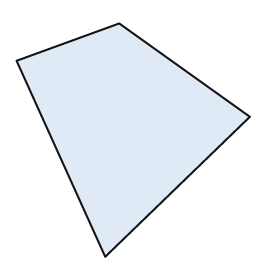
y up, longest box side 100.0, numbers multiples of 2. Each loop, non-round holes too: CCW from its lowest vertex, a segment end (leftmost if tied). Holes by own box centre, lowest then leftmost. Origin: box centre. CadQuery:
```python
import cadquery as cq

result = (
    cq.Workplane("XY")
    .moveTo(-12.0, -50.0)
    .lineTo(50.0, 10.0)
    .lineTo(-6.0, 50.0)
    .lineTo(-50.0, 34.0)
    .close()
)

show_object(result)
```